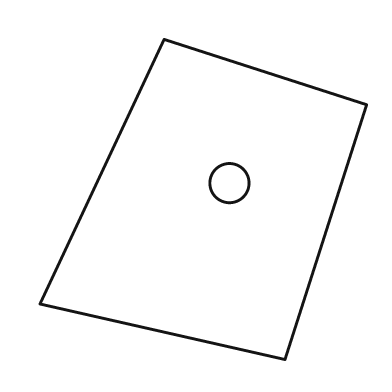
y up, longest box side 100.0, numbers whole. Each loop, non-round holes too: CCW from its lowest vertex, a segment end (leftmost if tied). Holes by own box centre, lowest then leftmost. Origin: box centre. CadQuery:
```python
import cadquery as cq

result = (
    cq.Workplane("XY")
    .moveTo(25.0, -49.0)
    .lineTo(50.0, 29.0)
    .lineTo(-12.0, 49.0)
    .lineTo(-50.0, -32.0)
    .close()
    .moveTo(8.0, 5.0)
    .circle(6.0)
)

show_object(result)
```